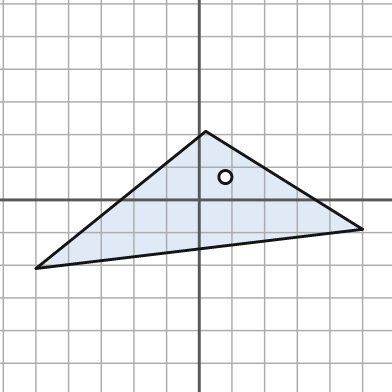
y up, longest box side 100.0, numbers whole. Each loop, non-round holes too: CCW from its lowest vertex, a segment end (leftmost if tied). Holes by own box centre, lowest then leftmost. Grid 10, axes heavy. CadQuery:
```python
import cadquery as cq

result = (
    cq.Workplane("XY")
    .moveTo(-50.0, -21.0)
    .lineTo(50.0, -9.0)
    .lineTo(2.0, 21.0)
    .close()
    .moveTo(8.0, 7.0)
    .circle(2.0)
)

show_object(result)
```